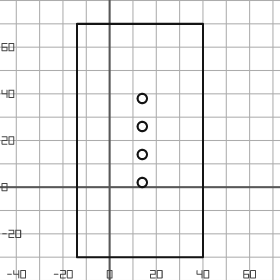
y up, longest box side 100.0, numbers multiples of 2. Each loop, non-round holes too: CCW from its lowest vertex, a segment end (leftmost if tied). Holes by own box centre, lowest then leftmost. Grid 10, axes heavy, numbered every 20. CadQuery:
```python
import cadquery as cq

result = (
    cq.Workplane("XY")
    .moveTo(-14.0, -30.0)
    .lineTo(40.0, -30.0)
    .lineTo(40.0, 70.0)
    .lineTo(-14.0, 70.0)
    .close()
    .moveTo(14.0, 2.0)
    .circle(2.0)
    .moveTo(14.0, 14.0)
    .circle(2.0)
    .moveTo(14.0, 26.0)
    .circle(2.0)
    .moveTo(14.0, 38.0)
    .circle(2.0)
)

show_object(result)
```